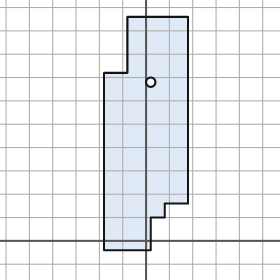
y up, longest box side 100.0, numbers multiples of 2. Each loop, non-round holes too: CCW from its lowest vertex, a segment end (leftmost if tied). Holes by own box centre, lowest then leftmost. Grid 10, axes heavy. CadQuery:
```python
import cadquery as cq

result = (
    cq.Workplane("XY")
    .moveTo(-18.0, -4.0)
    .lineTo(2.0, -4.0)
    .lineTo(2.0, 10.0)
    .lineTo(8.0, 10.0)
    .lineTo(8.0, 16.0)
    .lineTo(18.0, 16.0)
    .lineTo(18.0, 96.0)
    .lineTo(-8.0, 96.0)
    .lineTo(-8.0, 72.0)
    .lineTo(-18.0, 72.0)
    .close()
    .moveTo(2.0, 68.0)
    .circle(2.0)
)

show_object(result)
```